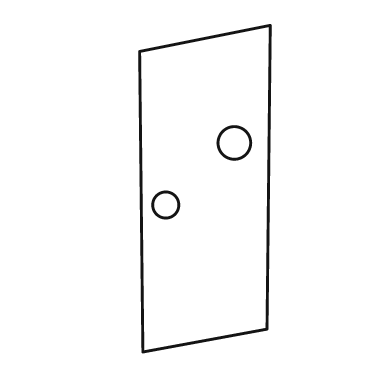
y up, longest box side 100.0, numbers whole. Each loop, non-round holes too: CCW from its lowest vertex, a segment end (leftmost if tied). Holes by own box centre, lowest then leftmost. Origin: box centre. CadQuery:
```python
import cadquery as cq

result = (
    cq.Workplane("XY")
    .moveTo(-19.0, -50.0)
    .lineTo(19.0, -43.0)
    .lineTo(20.0, 50.0)
    .lineTo(-20.0, 42.0)
    .close()
    .moveTo(-12.0, -5.0)
    .circle(4.0)
    .moveTo(9.0, 14.0)
    .circle(5.0)
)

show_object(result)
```